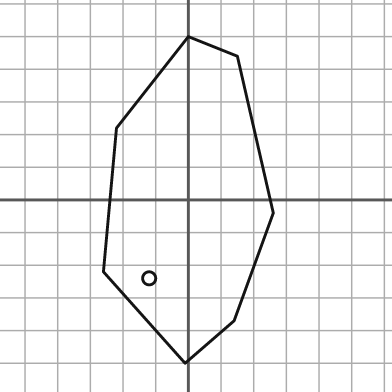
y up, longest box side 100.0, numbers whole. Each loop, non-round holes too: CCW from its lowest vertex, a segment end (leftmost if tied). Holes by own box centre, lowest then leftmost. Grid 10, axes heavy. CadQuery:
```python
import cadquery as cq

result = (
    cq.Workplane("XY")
    .moveTo(-1.0, -50.0)
    .lineTo(14.0, -37.0)
    .lineTo(26.0, -4.0)
    .lineTo(15.0, 44.0)
    .lineTo(0.0, 50.0)
    .lineTo(-22.0, 22.0)
    .lineTo(-26.0, -22.0)
    .close()
    .moveTo(-12.0, -24.0)
    .circle(2.0)
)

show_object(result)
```